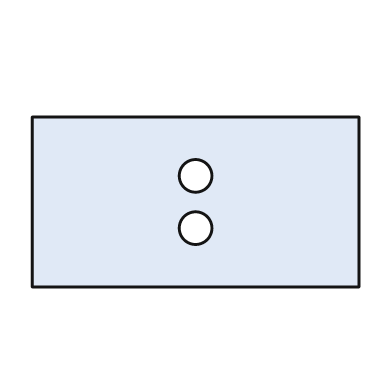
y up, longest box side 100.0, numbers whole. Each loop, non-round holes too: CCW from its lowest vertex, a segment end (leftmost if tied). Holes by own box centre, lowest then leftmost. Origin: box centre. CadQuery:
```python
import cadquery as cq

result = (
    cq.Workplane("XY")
    .moveTo(-50.0, -26.0)
    .lineTo(50.0, -26.0)
    .lineTo(50.0, 26.0)
    .lineTo(-50.0, 26.0)
    .close()
    .moveTo(0.0, -8.0)
    .circle(5.0)
    .moveTo(0.0, 8.0)
    .circle(5.0)
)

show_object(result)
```